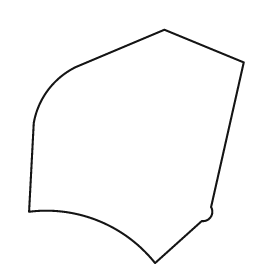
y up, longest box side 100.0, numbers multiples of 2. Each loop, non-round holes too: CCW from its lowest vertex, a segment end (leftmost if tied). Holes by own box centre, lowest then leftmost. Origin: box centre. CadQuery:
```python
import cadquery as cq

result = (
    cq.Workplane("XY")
    .moveTo(8.0, -50.0)
    .lineTo(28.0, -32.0)
    .threePointArc((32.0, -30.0), (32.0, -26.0))
    .lineTo(46.0, 36.0)
    .lineTo(12.0, 50.0)
    .lineTo(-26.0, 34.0)
    .threePointArc((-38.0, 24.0), (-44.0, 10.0))
    .lineTo(-46.0, -28.0)
    .threePointArc((-16.0, -32.0), (8.0, -50.0))
    .close()
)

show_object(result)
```